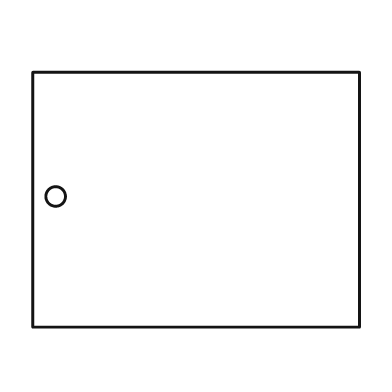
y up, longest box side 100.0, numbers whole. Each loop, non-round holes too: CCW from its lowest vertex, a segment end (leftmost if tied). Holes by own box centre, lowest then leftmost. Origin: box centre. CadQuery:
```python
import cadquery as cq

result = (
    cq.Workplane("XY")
    .moveTo(-50.0, -39.0)
    .lineTo(50.0, -39.0)
    .lineTo(50.0, 39.0)
    .lineTo(-50.0, 39.0)
    .close()
    .moveTo(-43.0, 1.0)
    .circle(3.0)
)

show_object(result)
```